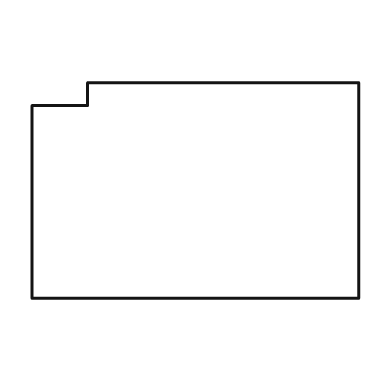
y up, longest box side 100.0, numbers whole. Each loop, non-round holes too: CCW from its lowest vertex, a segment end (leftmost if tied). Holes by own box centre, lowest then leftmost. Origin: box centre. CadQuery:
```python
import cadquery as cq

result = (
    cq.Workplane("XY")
    .moveTo(-50.0, -33.0)
    .lineTo(50.0, -33.0)
    .lineTo(50.0, 33.0)
    .lineTo(-33.0, 33.0)
    .lineTo(-33.0, 26.0)
    .lineTo(-50.0, 26.0)
    .close()
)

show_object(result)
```